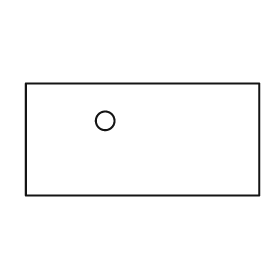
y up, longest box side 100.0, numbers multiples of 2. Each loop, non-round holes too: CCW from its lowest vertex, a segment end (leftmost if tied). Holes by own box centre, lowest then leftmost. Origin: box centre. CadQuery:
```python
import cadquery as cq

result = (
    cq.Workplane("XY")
    .moveTo(-50.0, -24.0)
    .lineTo(50.0, -24.0)
    .lineTo(50.0, 24.0)
    .lineTo(-50.0, 24.0)
    .close()
    .moveTo(-16.0, 8.0)
    .circle(4.0)
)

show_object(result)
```